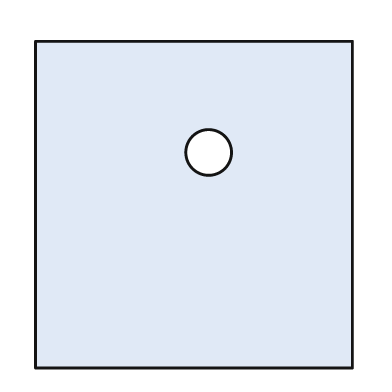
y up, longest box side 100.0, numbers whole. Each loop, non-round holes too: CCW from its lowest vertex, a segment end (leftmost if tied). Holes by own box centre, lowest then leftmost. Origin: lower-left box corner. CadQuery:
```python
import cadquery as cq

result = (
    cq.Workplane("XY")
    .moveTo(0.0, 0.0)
    .lineTo(97.0, 0.0)
    .lineTo(97.0, 100.0)
    .lineTo(0.0, 100.0)
    .close()
    .moveTo(53.0, 66.0)
    .circle(7.0)
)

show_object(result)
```